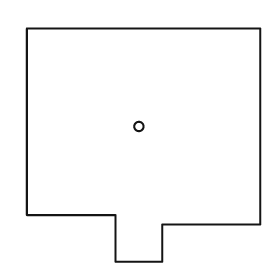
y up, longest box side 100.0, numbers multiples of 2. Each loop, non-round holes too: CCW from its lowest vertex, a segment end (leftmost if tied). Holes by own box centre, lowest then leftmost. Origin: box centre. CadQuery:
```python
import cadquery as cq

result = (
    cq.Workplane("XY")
    .moveTo(-12.0, -50.0)
    .lineTo(8.0, -50.0)
    .lineTo(8.0, -34.0)
    .lineTo(50.0, -34.0)
    .lineTo(50.0, 50.0)
    .lineTo(-50.0, 50.0)
    .lineTo(-50.0, -30.0)
    .lineTo(-12.0, -30.0)
    .close()
    .moveTo(-2.0, 8.0)
    .circle(2.0)
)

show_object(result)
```